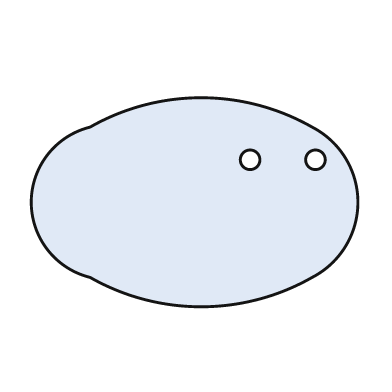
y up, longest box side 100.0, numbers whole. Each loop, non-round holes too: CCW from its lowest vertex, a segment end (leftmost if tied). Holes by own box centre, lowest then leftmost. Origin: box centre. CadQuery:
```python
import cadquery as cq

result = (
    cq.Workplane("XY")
    .moveTo(-32.0, -23.0)
    .threePointArc((2.0, -32.0), (36.0, -23.0))
    .threePointArc((50.0, 0.0), (36.0, 23.0))
    .threePointArc((2.0, 32.0), (-32.0, 23.0))
    .threePointArc((-50.0, 0.0), (-32.0, -23.0))
    .close()
    .moveTo(17.0, 13.0)
    .circle(3.0)
    .moveTo(37.0, 13.0)
    .circle(3.0)
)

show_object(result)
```